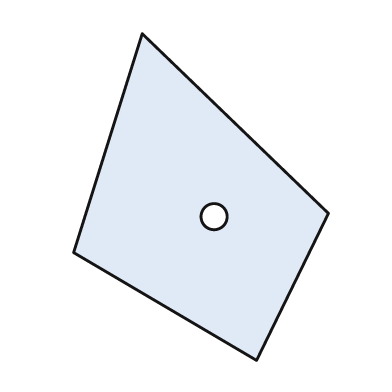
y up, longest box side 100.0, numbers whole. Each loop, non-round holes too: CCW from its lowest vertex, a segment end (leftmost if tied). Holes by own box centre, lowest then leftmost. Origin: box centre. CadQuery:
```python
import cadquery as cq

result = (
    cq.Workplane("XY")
    .moveTo(17.0, -50.0)
    .lineTo(39.0, -5.0)
    .lineTo(-18.0, 50.0)
    .lineTo(-39.0, -17.0)
    .close()
    .moveTo(4.0, -6.0)
    .circle(4.0)
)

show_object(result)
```